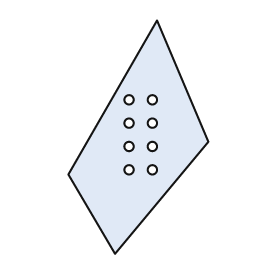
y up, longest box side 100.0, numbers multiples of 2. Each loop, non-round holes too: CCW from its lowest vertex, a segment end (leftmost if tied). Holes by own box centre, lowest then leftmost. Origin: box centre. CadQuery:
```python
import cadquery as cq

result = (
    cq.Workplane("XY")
    .moveTo(-10.0, -50.0)
    .lineTo(30.0, -2.0)
    .lineTo(8.0, 50.0)
    .lineTo(-30.0, -16.0)
    .close()
    .moveTo(-4.0, -14.0)
    .circle(2.0)
    .moveTo(6.0, -14.0)
    .circle(2.0)
    .moveTo(-4.0, -4.0)
    .circle(2.0)
    .moveTo(6.0, -4.0)
    .circle(2.0)
    .moveTo(-4.0, 6.0)
    .circle(2.0)
    .moveTo(6.0, 6.0)
    .circle(2.0)
    .moveTo(-4.0, 16.0)
    .circle(2.0)
    .moveTo(6.0, 16.0)
    .circle(2.0)
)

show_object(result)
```